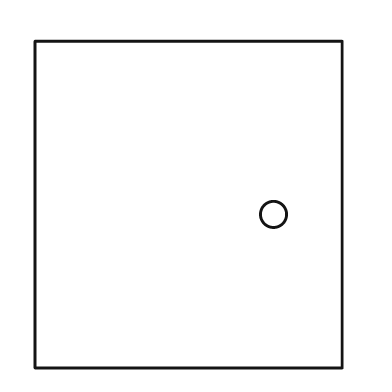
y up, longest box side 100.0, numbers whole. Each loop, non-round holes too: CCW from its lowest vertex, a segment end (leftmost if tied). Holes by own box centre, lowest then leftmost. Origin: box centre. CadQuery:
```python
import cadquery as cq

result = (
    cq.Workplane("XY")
    .moveTo(-47.0, -50.0)
    .lineTo(47.0, -50.0)
    .lineTo(47.0, 50.0)
    .lineTo(-47.0, 50.0)
    .close()
    .moveTo(26.0, -3.0)
    .circle(4.0)
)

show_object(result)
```